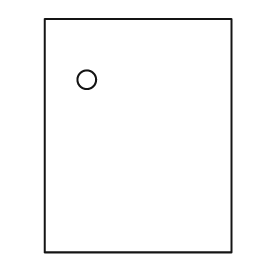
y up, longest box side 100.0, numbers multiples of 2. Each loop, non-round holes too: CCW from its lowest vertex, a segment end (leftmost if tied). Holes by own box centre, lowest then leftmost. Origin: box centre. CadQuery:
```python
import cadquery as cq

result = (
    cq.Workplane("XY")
    .moveTo(-40.0, -50.0)
    .lineTo(40.0, -50.0)
    .lineTo(40.0, 50.0)
    .lineTo(-40.0, 50.0)
    .close()
    .moveTo(-22.0, 24.0)
    .circle(4.0)
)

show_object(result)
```